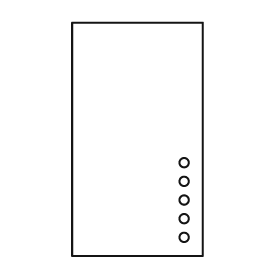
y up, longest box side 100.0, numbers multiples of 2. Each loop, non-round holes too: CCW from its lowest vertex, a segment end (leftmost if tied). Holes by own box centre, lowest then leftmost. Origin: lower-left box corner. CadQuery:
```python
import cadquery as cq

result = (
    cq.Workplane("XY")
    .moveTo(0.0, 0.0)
    .lineTo(56.0, 0.0)
    .lineTo(56.0, 100.0)
    .lineTo(0.0, 100.0)
    .close()
    .moveTo(48.0, 8.0)
    .circle(2.0)
    .moveTo(48.0, 16.0)
    .circle(2.0)
    .moveTo(48.0, 24.0)
    .circle(2.0)
    .moveTo(48.0, 32.0)
    .circle(2.0)
    .moveTo(48.0, 40.0)
    .circle(2.0)
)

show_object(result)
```